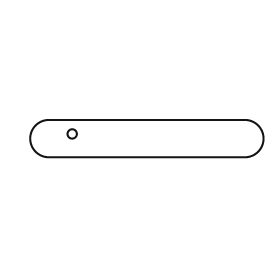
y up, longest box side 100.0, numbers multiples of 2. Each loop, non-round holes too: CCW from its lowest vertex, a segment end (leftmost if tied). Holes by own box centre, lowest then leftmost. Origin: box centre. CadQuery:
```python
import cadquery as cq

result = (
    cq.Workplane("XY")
    .moveTo(-42.0, -8.0)
    .lineTo(42.0, -8.0)
    .threePointArc((50.0, 0.0), (42.0, 8.0))
    .lineTo(-42.0, 8.0)
    .threePointArc((-50.0, 0.0), (-42.0, -8.0))
    .close()
    .moveTo(-32.0, 2.0)
    .circle(2.0)
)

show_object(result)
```